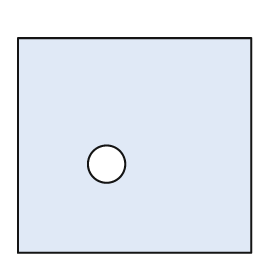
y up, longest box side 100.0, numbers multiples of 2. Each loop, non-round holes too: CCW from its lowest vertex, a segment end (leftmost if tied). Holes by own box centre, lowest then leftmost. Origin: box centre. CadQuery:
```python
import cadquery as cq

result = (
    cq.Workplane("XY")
    .moveTo(-50.0, -46.0)
    .lineTo(50.0, -46.0)
    .lineTo(50.0, 46.0)
    .lineTo(-50.0, 46.0)
    .close()
    .moveTo(-12.0, -8.0)
    .circle(8.0)
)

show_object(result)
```